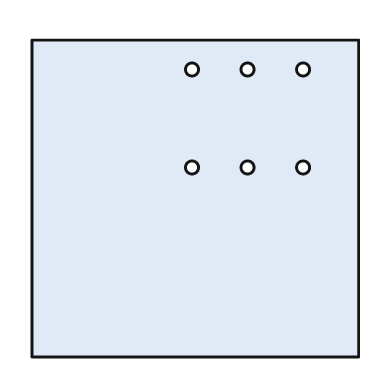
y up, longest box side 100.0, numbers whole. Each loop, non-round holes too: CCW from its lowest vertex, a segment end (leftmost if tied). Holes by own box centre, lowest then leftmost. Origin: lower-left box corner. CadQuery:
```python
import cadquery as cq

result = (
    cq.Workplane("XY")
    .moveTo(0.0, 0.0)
    .lineTo(100.0, 0.0)
    .lineTo(100.0, 97.0)
    .lineTo(0.0, 97.0)
    .close()
    .moveTo(49.0, 58.0)
    .circle(2.0)
    .moveTo(66.0, 58.0)
    .circle(2.0)
    .moveTo(83.0, 58.0)
    .circle(2.0)
    .moveTo(49.0, 88.0)
    .circle(2.0)
    .moveTo(66.0, 88.0)
    .circle(2.0)
    .moveTo(83.0, 88.0)
    .circle(2.0)
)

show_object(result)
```